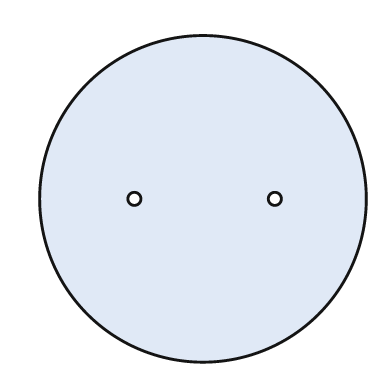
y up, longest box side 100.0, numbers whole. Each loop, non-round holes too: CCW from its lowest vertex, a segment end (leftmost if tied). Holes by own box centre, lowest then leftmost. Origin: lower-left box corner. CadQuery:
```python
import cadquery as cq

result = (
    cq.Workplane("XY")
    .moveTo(50.0, 50.0)
    .circle(50.0)
    .moveTo(29.0, 50.0)
    .circle(2.0)
    .moveTo(72.0, 50.0)
    .circle(2.0)
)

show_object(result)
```